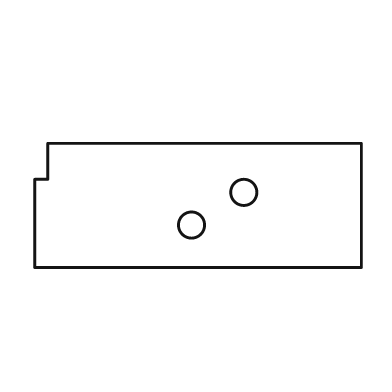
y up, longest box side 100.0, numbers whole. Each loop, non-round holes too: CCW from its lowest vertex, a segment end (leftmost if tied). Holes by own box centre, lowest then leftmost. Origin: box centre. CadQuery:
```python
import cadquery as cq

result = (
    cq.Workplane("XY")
    .moveTo(-50.0, -19.0)
    .lineTo(50.0, -19.0)
    .lineTo(50.0, 19.0)
    .lineTo(-46.0, 19.0)
    .lineTo(-46.0, 8.0)
    .lineTo(-50.0, 8.0)
    .close()
    .moveTo(-2.0, -6.0)
    .circle(4.0)
    .moveTo(14.0, 4.0)
    .circle(4.0)
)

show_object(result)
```